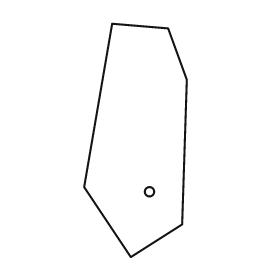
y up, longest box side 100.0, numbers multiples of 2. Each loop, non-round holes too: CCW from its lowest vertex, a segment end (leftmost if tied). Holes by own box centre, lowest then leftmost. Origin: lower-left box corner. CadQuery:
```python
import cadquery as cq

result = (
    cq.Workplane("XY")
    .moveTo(20.0, 0.0)
    .lineTo(42.0, 14.0)
    .lineTo(44.0, 76.0)
    .lineTo(36.0, 98.0)
    .lineTo(12.0, 100.0)
    .lineTo(0.0, 30.0)
    .close()
    .moveTo(28.0, 28.0)
    .circle(2.0)
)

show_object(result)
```